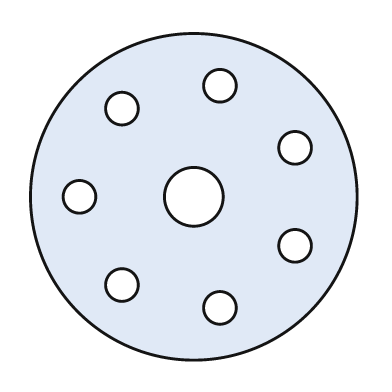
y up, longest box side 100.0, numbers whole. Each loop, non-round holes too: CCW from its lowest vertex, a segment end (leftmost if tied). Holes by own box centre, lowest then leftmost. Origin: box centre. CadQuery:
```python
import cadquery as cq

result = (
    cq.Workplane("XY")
    .moveTo(0.0, 0.0)
    .circle(50.0)
    .moveTo(8.0, -34.0)
    .circle(5.0)
    .moveTo(-22.0, -27.0)
    .circle(5.0)
    .moveTo(31.0, -15.0)
    .circle(5.0)
    .moveTo(-35.0, 0.0)
    .circle(5.0)
    .moveTo(0.0, 0.0)
    .circle(9.0)
    .moveTo(31.0, 15.0)
    .circle(5.0)
    .moveTo(-22.0, 27.0)
    .circle(5.0)
    .moveTo(8.0, 34.0)
    .circle(5.0)
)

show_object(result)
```